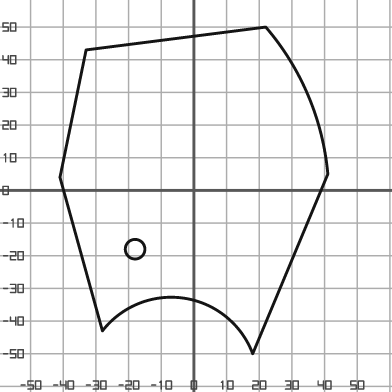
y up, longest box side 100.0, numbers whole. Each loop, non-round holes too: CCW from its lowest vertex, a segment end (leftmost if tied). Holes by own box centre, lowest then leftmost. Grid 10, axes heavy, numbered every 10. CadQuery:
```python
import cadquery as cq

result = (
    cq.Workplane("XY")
    .moveTo(18.0, -50.0)
    .lineTo(41.0, 5.0)
    .threePointArc((35.0, 29.0), (22.0, 50.0))
    .lineTo(-33.0, 43.0)
    .lineTo(-41.0, 4.0)
    .lineTo(-28.0, -43.0)
    .threePointArc((-3.0, -33.0), (18.0, -50.0))
    .close()
    .moveTo(-18.0, -18.0)
    .circle(3.0)
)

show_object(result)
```